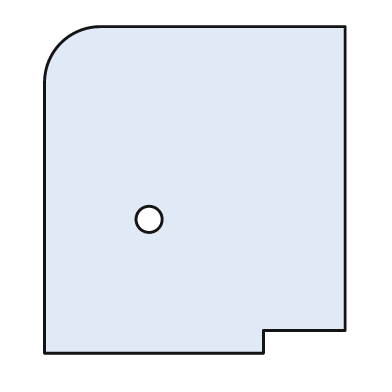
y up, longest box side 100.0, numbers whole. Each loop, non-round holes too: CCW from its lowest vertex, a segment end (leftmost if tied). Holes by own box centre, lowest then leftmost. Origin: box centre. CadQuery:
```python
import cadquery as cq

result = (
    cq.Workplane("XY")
    .moveTo(-46.0, -50.0)
    .lineTo(21.0, -50.0)
    .lineTo(21.0, -43.0)
    .lineTo(46.0, -43.0)
    .lineTo(46.0, 50.0)
    .lineTo(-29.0, 50.0)
    .threePointArc((-41.0, 45.0), (-46.0, 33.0))
    .close()
    .moveTo(-14.0, -9.0)
    .circle(4.0)
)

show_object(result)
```